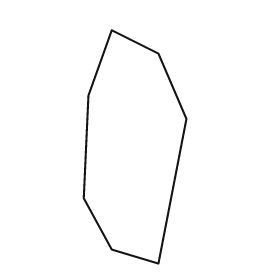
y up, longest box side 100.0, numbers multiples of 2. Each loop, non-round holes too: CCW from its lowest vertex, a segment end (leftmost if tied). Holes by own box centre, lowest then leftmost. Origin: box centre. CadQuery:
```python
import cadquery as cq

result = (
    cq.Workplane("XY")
    .moveTo(10.0, -50.0)
    .lineTo(22.0, 12.0)
    .lineTo(10.0, 40.0)
    .lineTo(-10.0, 50.0)
    .lineTo(-20.0, 22.0)
    .lineTo(-22.0, -22.0)
    .lineTo(-10.0, -44.0)
    .close()
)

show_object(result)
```